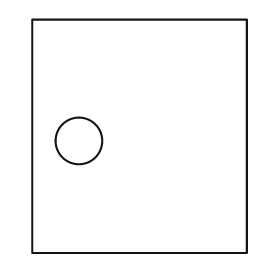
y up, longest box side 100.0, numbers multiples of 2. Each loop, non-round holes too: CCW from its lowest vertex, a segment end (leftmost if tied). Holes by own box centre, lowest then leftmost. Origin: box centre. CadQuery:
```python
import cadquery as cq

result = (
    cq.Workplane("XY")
    .moveTo(-46.0, -50.0)
    .lineTo(46.0, -50.0)
    .lineTo(46.0, 50.0)
    .lineTo(-46.0, 50.0)
    .close()
    .moveTo(-26.0, -2.0)
    .circle(10.0)
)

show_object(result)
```